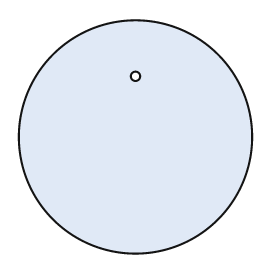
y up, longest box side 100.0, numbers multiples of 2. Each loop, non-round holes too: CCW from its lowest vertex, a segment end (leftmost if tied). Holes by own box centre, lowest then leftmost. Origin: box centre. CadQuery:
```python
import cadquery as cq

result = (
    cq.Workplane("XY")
    .moveTo(0.0, 0.0)
    .circle(50.0)
    .moveTo(0.0, 26.0)
    .circle(2.0)
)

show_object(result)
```